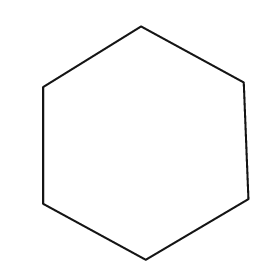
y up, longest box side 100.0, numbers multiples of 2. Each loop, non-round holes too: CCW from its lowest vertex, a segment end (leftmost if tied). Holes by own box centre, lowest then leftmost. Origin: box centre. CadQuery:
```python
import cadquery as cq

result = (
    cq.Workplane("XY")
    .moveTo(0.0, -50.0)
    .lineTo(44.0, -24.0)
    .lineTo(42.0, 26.0)
    .lineTo(-2.0, 50.0)
    .lineTo(-44.0, 24.0)
    .lineTo(-44.0, -26.0)
    .close()
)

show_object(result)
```